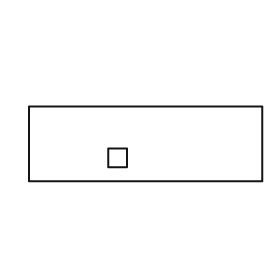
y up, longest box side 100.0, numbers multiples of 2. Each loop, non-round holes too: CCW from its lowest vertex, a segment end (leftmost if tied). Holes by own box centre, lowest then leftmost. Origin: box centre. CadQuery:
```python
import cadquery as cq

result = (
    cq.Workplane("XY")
    .moveTo(-50.0, -16.0)
    .lineTo(50.0, -16.0)
    .lineTo(50.0, 16.0)
    .lineTo(-50.0, 16.0)
    .close()
    .moveTo(-16.0, -10.0)
    .lineTo(-8.0, -10.0)
    .lineTo(-8.0, -2.0)
    .lineTo(-16.0, -2.0)
    .close()
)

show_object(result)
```